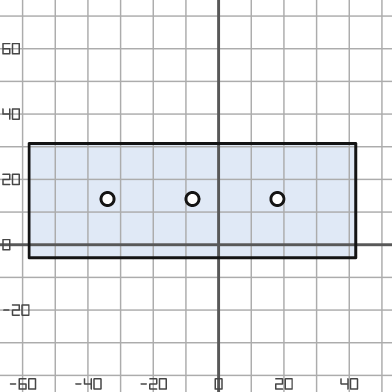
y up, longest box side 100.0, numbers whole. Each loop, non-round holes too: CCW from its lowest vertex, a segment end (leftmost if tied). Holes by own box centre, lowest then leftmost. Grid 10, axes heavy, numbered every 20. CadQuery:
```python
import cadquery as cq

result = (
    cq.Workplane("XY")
    .moveTo(-58.0, -4.0)
    .lineTo(42.0, -4.0)
    .lineTo(42.0, 31.0)
    .lineTo(-58.0, 31.0)
    .close()
    .moveTo(-34.0, 14.0)
    .circle(2.0)
    .moveTo(-8.0, 14.0)
    .circle(2.0)
    .moveTo(18.0, 14.0)
    .circle(2.0)
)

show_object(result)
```